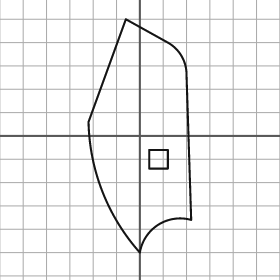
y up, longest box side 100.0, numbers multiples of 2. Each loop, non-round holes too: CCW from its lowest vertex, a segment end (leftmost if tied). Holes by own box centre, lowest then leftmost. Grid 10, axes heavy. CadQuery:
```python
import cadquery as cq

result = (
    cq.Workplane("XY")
    .moveTo(0.0, -50.0)
    .threePointArc((8.0, -38.0), (22.0, -36.0))
    .lineTo(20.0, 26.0)
    .threePointArc((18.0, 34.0), (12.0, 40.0))
    .lineTo(-6.0, 50.0)
    .lineTo(-22.0, 6.0)
    .threePointArc((-16.0, -24.0), (0.0, -50.0))
    .close()
    .moveTo(4.0, -14.0)
    .lineTo(12.0, -14.0)
    .lineTo(12.0, -6.0)
    .lineTo(4.0, -6.0)
    .close()
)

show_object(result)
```